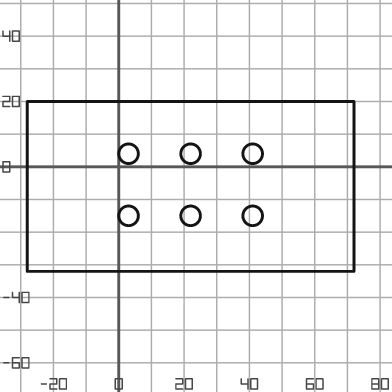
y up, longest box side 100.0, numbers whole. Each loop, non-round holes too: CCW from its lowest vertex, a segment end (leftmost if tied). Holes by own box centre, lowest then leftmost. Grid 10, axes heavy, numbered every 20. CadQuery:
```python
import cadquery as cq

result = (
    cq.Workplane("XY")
    .moveTo(-28.0, -32.0)
    .lineTo(72.0, -32.0)
    .lineTo(72.0, 20.0)
    .lineTo(-28.0, 20.0)
    .close()
    .moveTo(3.0, -15.0)
    .circle(3.0)
    .moveTo(22.0, -15.0)
    .circle(3.0)
    .moveTo(41.0, -15.0)
    .circle(3.0)
    .moveTo(3.0, 4.0)
    .circle(3.0)
    .moveTo(22.0, 4.0)
    .circle(3.0)
    .moveTo(41.0, 4.0)
    .circle(3.0)
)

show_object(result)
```